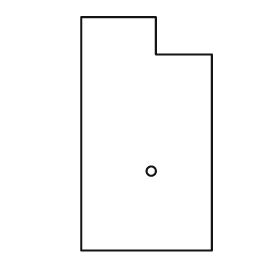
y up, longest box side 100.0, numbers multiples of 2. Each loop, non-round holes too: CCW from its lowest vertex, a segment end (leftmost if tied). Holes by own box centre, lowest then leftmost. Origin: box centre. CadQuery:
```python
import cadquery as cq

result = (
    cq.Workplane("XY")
    .moveTo(-28.0, -50.0)
    .lineTo(28.0, -50.0)
    .lineTo(28.0, 34.0)
    .lineTo(4.0, 34.0)
    .lineTo(4.0, 50.0)
    .lineTo(-28.0, 50.0)
    .close()
    .moveTo(2.0, -16.0)
    .circle(2.0)
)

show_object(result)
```